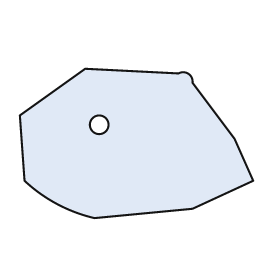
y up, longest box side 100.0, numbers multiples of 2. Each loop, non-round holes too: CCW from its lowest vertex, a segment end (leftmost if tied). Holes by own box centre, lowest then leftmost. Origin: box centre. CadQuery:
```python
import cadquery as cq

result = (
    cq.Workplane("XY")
    .moveTo(-18.0, -32.0)
    .lineTo(24.0, -28.0)
    .lineTo(50.0, -16.0)
    .lineTo(42.0, 2.0)
    .lineTo(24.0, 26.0)
    .threePointArc((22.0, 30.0), (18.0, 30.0))
    .lineTo(-22.0, 32.0)
    .lineTo(-50.0, 12.0)
    .lineTo(-48.0, -16.0)
    .threePointArc((-34.0, -26.0), (-18.0, -32.0))
    .close()
    .moveTo(-16.0, 8.0)
    .circle(4.0)
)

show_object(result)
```